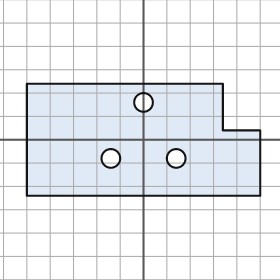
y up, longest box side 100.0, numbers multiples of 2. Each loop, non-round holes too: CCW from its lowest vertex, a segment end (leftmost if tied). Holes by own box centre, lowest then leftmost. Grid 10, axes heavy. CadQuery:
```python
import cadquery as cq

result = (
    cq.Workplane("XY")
    .moveTo(-50.0, -24.0)
    .lineTo(50.0, -24.0)
    .lineTo(50.0, 4.0)
    .lineTo(34.0, 4.0)
    .lineTo(34.0, 24.0)
    .lineTo(-50.0, 24.0)
    .close()
    .moveTo(-14.0, -8.0)
    .circle(4.0)
    .moveTo(14.0, -8.0)
    .circle(4.0)
    .moveTo(0.0, 16.0)
    .circle(4.0)
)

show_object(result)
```